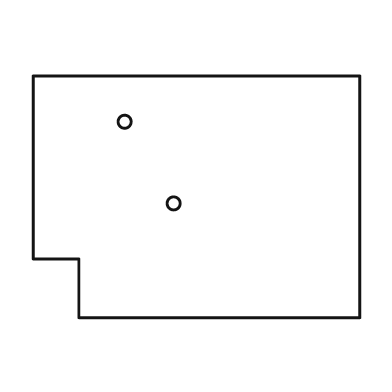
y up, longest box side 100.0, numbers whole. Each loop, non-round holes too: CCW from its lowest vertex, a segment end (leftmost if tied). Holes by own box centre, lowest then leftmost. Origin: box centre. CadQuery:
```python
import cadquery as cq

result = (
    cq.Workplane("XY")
    .moveTo(-36.0, -37.0)
    .lineTo(50.0, -37.0)
    .lineTo(50.0, 37.0)
    .lineTo(-50.0, 37.0)
    .lineTo(-50.0, -19.0)
    .lineTo(-36.0, -19.0)
    .close()
    .moveTo(-7.0, -2.0)
    .circle(2.0)
    .moveTo(-22.0, 23.0)
    .circle(2.0)
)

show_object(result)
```